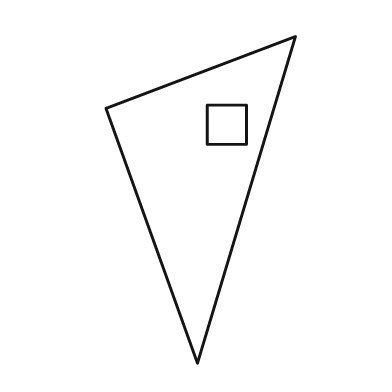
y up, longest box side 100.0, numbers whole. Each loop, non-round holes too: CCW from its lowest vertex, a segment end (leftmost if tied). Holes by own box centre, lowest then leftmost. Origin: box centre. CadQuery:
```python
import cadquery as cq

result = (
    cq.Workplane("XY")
    .moveTo(-1.0, -50.0)
    .lineTo(29.0, 50.0)
    .lineTo(-29.0, 28.0)
    .close()
    .moveTo(2.0, 17.0)
    .lineTo(14.0, 17.0)
    .lineTo(14.0, 29.0)
    .lineTo(2.0, 29.0)
    .close()
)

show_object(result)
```